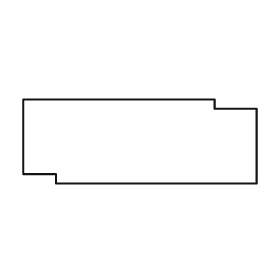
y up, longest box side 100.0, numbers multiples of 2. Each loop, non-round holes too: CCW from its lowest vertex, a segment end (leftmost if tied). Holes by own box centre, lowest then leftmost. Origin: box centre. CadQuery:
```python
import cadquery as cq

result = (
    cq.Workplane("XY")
    .moveTo(-36.0, -18.0)
    .lineTo(50.0, -18.0)
    .lineTo(50.0, 14.0)
    .lineTo(32.0, 14.0)
    .lineTo(32.0, 18.0)
    .lineTo(-50.0, 18.0)
    .lineTo(-50.0, -14.0)
    .lineTo(-36.0, -14.0)
    .close()
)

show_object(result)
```